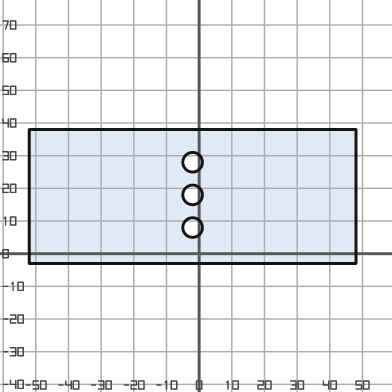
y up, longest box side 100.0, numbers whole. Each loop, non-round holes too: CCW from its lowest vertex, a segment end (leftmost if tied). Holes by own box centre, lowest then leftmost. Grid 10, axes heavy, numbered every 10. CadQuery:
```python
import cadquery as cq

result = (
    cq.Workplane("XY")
    .moveTo(-52.0, -3.0)
    .lineTo(48.0, -3.0)
    .lineTo(48.0, 38.0)
    .lineTo(-52.0, 38.0)
    .close()
    .moveTo(-2.0, 8.0)
    .circle(3.0)
    .moveTo(-2.0, 18.0)
    .circle(3.0)
    .moveTo(-2.0, 28.0)
    .circle(3.0)
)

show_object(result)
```